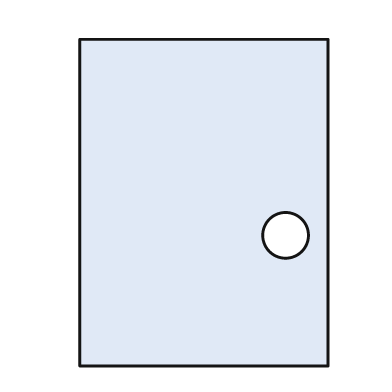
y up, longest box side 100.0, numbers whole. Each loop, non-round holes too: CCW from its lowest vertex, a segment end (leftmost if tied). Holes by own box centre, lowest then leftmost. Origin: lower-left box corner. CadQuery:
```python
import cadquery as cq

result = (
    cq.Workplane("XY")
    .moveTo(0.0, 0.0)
    .lineTo(76.0, 0.0)
    .lineTo(76.0, 100.0)
    .lineTo(0.0, 100.0)
    .close()
    .moveTo(63.0, 40.0)
    .circle(7.0)
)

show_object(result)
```